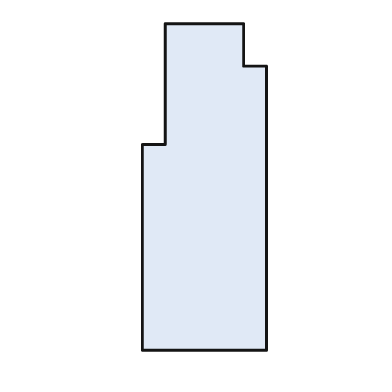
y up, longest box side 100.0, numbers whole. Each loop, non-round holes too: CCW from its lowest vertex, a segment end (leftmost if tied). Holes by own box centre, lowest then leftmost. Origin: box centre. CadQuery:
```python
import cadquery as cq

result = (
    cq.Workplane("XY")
    .moveTo(-19.0, -50.0)
    .lineTo(19.0, -50.0)
    .lineTo(19.0, 37.0)
    .lineTo(12.0, 37.0)
    .lineTo(12.0, 50.0)
    .lineTo(-12.0, 50.0)
    .lineTo(-12.0, 13.0)
    .lineTo(-19.0, 13.0)
    .close()
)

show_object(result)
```